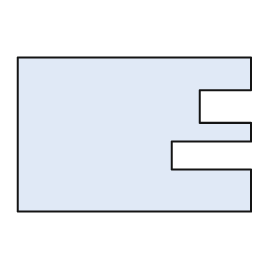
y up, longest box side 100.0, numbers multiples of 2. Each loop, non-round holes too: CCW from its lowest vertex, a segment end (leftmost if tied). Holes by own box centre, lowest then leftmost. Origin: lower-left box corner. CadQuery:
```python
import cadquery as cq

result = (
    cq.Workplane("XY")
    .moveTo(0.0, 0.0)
    .lineTo(100.0, 0.0)
    .lineTo(100.0, 18.0)
    .lineTo(66.0, 18.0)
    .lineTo(66.0, 30.0)
    .lineTo(100.0, 30.0)
    .lineTo(100.0, 38.0)
    .lineTo(78.0, 38.0)
    .lineTo(78.0, 52.0)
    .lineTo(100.0, 52.0)
    .lineTo(100.0, 66.0)
    .lineTo(0.0, 66.0)
    .close()
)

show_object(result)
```